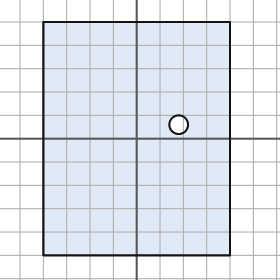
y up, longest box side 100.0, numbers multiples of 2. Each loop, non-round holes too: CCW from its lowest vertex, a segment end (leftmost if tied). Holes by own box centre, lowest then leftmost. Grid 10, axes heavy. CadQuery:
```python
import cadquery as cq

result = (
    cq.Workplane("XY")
    .moveTo(-40.0, -50.0)
    .lineTo(40.0, -50.0)
    .lineTo(40.0, 50.0)
    .lineTo(-40.0, 50.0)
    .close()
    .moveTo(18.0, 6.0)
    .circle(4.0)
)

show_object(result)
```